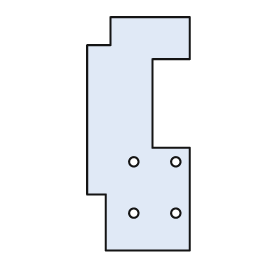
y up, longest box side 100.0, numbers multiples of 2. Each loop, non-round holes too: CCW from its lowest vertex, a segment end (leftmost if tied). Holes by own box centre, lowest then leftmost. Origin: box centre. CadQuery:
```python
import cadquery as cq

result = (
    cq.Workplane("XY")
    .moveTo(-14.0, -50.0)
    .lineTo(22.0, -50.0)
    .lineTo(22.0, -6.0)
    .lineTo(6.0, -6.0)
    .lineTo(6.0, 32.0)
    .lineTo(22.0, 32.0)
    .lineTo(22.0, 50.0)
    .lineTo(-12.0, 50.0)
    .lineTo(-12.0, 38.0)
    .lineTo(-22.0, 38.0)
    .lineTo(-22.0, -26.0)
    .lineTo(-14.0, -26.0)
    .close()
    .moveTo(-2.0, -34.0)
    .circle(2.0)
    .moveTo(16.0, -34.0)
    .circle(2.0)
    .moveTo(-2.0, -12.0)
    .circle(2.0)
    .moveTo(16.0, -12.0)
    .circle(2.0)
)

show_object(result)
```